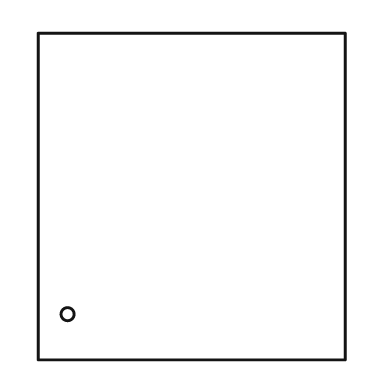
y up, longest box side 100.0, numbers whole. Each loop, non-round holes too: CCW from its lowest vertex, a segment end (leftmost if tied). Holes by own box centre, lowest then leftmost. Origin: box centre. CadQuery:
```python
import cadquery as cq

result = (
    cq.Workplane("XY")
    .moveTo(-47.0, -50.0)
    .lineTo(47.0, -50.0)
    .lineTo(47.0, 50.0)
    .lineTo(-47.0, 50.0)
    .close()
    .moveTo(-38.0, -36.0)
    .circle(2.0)
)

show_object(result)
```